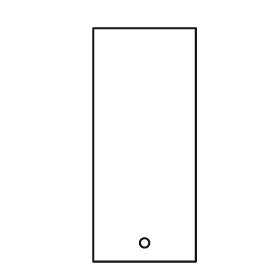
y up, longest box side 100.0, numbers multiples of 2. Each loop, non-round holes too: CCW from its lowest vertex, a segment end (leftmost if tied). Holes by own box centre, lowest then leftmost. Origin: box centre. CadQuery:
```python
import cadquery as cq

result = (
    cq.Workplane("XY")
    .moveTo(-22.0, -50.0)
    .lineTo(22.0, -50.0)
    .lineTo(22.0, 50.0)
    .lineTo(-22.0, 50.0)
    .close()
    .moveTo(0.0, -42.0)
    .circle(2.0)
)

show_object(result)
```